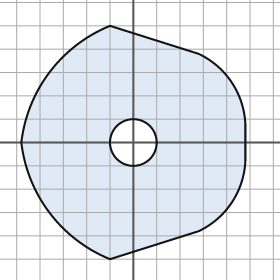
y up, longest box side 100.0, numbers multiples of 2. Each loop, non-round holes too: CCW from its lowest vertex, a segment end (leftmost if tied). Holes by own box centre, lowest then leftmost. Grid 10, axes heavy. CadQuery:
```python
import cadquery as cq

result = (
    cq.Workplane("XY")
    .moveTo(-10.0, -50.0)
    .lineTo(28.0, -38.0)
    .threePointArc((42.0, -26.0), (48.0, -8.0))
    .lineTo(48.0, 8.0)
    .threePointArc((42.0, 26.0), (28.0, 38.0))
    .lineTo(-10.0, 50.0)
    .threePointArc((-36.0, 30.0), (-48.0, 0.0))
    .threePointArc((-36.0, -30.0), (-10.0, -50.0))
    .close()
    .moveTo(0.0, 0.0)
    .circle(10.0)
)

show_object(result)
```